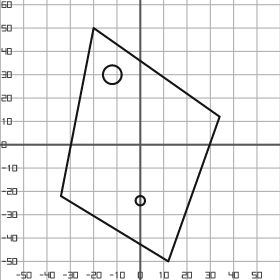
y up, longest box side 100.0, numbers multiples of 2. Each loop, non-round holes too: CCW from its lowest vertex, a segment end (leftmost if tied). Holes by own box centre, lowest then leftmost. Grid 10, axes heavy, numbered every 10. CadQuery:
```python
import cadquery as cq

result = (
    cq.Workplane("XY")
    .moveTo(12.0, -50.0)
    .lineTo(34.0, 12.0)
    .lineTo(-20.0, 50.0)
    .lineTo(-34.0, -22.0)
    .close()
    .moveTo(0.0, -24.0)
    .circle(2.0)
    .moveTo(-12.0, 30.0)
    .circle(4.0)
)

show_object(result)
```